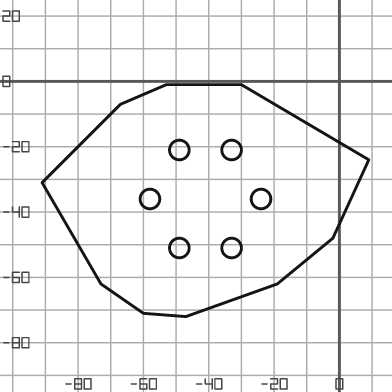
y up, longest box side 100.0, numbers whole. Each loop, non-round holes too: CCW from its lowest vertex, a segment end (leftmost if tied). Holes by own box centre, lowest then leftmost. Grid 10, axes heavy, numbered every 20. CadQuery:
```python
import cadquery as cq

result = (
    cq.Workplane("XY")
    .moveTo(-47.0, -72.0)
    .lineTo(-19.0, -62.0)
    .lineTo(-2.0, -48.0)
    .lineTo(9.0, -24.0)
    .lineTo(-30.0, -1.0)
    .lineTo(-53.0, -1.0)
    .lineTo(-67.0, -7.0)
    .lineTo(-91.0, -31.0)
    .lineTo(-73.0, -62.0)
    .lineTo(-60.0, -71.0)
    .close()
    .moveTo(-49.0, -51.0)
    .circle(3.0)
    .moveTo(-33.0, -51.0)
    .circle(3.0)
    .moveTo(-58.0, -36.0)
    .circle(3.0)
    .moveTo(-24.0, -36.0)
    .circle(3.0)
    .moveTo(-49.0, -21.0)
    .circle(3.0)
    .moveTo(-33.0, -21.0)
    .circle(3.0)
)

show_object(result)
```